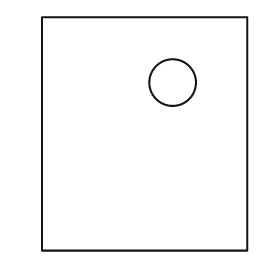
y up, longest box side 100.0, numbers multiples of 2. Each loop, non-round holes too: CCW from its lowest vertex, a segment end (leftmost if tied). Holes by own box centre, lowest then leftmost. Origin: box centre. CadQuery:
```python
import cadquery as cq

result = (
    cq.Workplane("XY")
    .moveTo(-44.0, -50.0)
    .lineTo(44.0, -50.0)
    .lineTo(44.0, 50.0)
    .lineTo(-44.0, 50.0)
    .close()
    .moveTo(12.0, 22.0)
    .circle(10.0)
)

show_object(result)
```